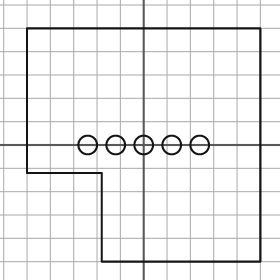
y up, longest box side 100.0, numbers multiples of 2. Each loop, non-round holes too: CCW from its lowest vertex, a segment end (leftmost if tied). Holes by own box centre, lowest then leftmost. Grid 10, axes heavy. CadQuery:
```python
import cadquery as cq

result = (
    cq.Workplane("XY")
    .moveTo(-18.0, -50.0)
    .lineTo(50.0, -50.0)
    .lineTo(50.0, 50.0)
    .lineTo(-50.0, 50.0)
    .lineTo(-50.0, -12.0)
    .lineTo(-18.0, -12.0)
    .close()
    .moveTo(-24.0, 0.0)
    .circle(4.0)
    .moveTo(-12.0, 0.0)
    .circle(4.0)
    .moveTo(0.0, 0.0)
    .circle(4.0)
    .moveTo(12.0, 0.0)
    .circle(4.0)
    .moveTo(24.0, 0.0)
    .circle(4.0)
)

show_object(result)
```